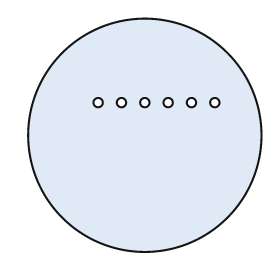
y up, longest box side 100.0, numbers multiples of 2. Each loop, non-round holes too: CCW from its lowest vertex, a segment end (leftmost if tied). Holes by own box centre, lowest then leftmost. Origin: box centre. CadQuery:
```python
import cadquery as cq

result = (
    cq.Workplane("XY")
    .moveTo(0.0, 0.0)
    .circle(50.0)
    .moveTo(-20.0, 14.0)
    .circle(2.0)
    .moveTo(-10.0, 14.0)
    .circle(2.0)
    .moveTo(0.0, 14.0)
    .circle(2.0)
    .moveTo(10.0, 14.0)
    .circle(2.0)
    .moveTo(20.0, 14.0)
    .circle(2.0)
    .moveTo(30.0, 14.0)
    .circle(2.0)
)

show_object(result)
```